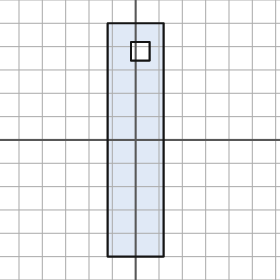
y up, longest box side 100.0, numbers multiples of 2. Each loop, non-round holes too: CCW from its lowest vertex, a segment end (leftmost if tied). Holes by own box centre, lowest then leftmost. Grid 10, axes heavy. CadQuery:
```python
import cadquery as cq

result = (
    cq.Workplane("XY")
    .moveTo(-12.0, -50.0)
    .lineTo(12.0, -50.0)
    .lineTo(12.0, 50.0)
    .lineTo(-12.0, 50.0)
    .close()
    .moveTo(-2.0, 34.0)
    .lineTo(6.0, 34.0)
    .lineTo(6.0, 42.0)
    .lineTo(-2.0, 42.0)
    .close()
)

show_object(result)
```